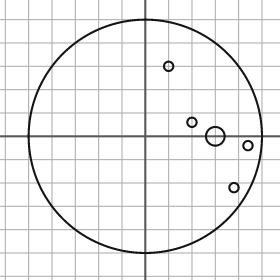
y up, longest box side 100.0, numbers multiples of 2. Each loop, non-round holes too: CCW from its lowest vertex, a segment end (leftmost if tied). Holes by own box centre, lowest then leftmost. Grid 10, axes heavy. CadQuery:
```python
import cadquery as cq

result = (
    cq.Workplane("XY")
    .moveTo(0.0, 0.0)
    .circle(50.0)
    .moveTo(38.0, -22.0)
    .circle(2.0)
    .moveTo(44.0, -4.0)
    .circle(2.0)
    .moveTo(30.0, 0.0)
    .circle(4.0)
    .moveTo(20.0, 6.0)
    .circle(2.0)
    .moveTo(10.0, 30.0)
    .circle(2.0)
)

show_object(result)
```